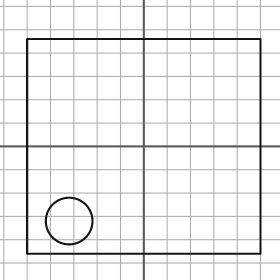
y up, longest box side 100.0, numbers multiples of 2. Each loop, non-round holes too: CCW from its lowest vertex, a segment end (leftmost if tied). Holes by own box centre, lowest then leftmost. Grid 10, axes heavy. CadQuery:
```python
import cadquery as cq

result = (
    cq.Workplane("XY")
    .moveTo(-50.0, -46.0)
    .lineTo(50.0, -46.0)
    .lineTo(50.0, 46.0)
    .lineTo(-50.0, 46.0)
    .close()
    .moveTo(-32.0, -32.0)
    .circle(10.0)
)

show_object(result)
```